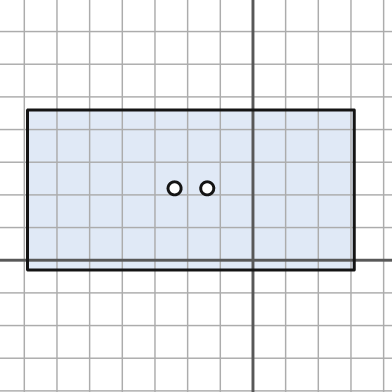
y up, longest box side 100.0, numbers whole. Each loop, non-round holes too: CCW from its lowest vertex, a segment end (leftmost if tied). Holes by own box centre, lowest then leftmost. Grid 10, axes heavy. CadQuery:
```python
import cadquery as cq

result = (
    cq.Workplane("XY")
    .moveTo(-69.0, -3.0)
    .lineTo(31.0, -3.0)
    .lineTo(31.0, 46.0)
    .lineTo(-69.0, 46.0)
    .close()
    .moveTo(-24.0, 22.0)
    .circle(2.0)
    .moveTo(-14.0, 22.0)
    .circle(2.0)
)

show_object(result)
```